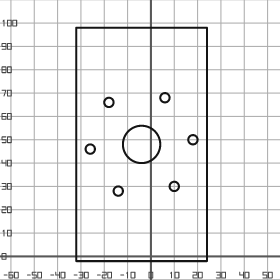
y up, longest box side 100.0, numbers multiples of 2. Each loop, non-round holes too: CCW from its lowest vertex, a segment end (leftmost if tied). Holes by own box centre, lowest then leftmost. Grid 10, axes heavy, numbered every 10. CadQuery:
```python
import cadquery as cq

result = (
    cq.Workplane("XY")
    .moveTo(-32.0, -2.0)
    .lineTo(24.0, -2.0)
    .lineTo(24.0, 98.0)
    .lineTo(-32.0, 98.0)
    .close()
    .moveTo(-14.0, 28.0)
    .circle(2.0)
    .moveTo(10.0, 30.0)
    .circle(2.0)
    .moveTo(-26.0, 46.0)
    .circle(2.0)
    .moveTo(-4.0, 48.0)
    .circle(8.0)
    .moveTo(18.0, 50.0)
    .circle(2.0)
    .moveTo(-18.0, 66.0)
    .circle(2.0)
    .moveTo(6.0, 68.0)
    .circle(2.0)
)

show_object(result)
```